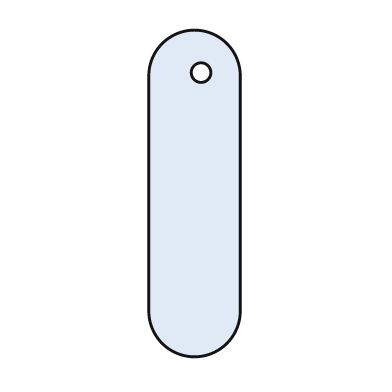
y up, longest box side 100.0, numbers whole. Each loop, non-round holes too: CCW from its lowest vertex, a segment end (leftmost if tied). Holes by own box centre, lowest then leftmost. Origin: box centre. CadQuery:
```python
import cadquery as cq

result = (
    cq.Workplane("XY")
    .moveTo(-14.0, -36.0)
    .threePointArc((0.0, -50.0), (14.0, -36.0))
    .lineTo(14.0, 36.0)
    .threePointArc((0.0, 50.0), (-14.0, 36.0))
    .close()
    .moveTo(2.0, 37.0)
    .circle(3.0)
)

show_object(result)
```